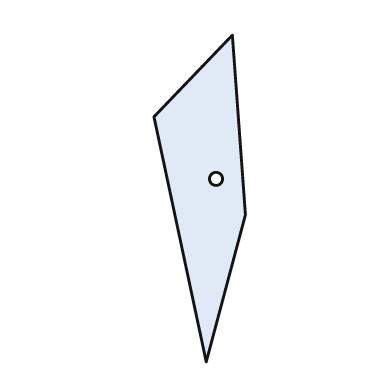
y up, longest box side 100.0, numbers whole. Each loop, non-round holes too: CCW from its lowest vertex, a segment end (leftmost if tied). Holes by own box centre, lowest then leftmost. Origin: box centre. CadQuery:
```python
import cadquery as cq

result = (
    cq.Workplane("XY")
    .moveTo(2.0, -50.0)
    .lineTo(14.0, -5.0)
    .lineTo(10.0, 50.0)
    .lineTo(-14.0, 25.0)
    .close()
    .moveTo(5.0, 6.0)
    .circle(2.0)
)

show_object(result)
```